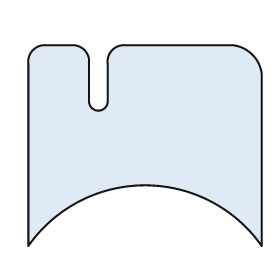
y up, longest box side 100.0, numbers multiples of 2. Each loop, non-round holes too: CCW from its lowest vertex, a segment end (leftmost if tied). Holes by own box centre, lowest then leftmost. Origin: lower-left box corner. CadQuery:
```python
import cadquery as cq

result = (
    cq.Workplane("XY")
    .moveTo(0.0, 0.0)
    .threePointArc((50.0, 26.0), (100.0, 0.0))
    .lineTo(100.0, 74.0)
    .threePointArc((96.0, 82.0), (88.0, 86.0))
    .lineTo(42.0, 86.0)
    .threePointArc((36.0, 84.0), (34.0, 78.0))
    .lineTo(34.0, 62.0)
    .threePointArc((30.0, 58.0), (26.0, 62.0))
    .lineTo(26.0, 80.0)
    .threePointArc((24.0, 84.0), (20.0, 86.0))
    .lineTo(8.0, 86.0)
    .threePointArc((2.0, 84.0), (0.0, 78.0))
    .close()
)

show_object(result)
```